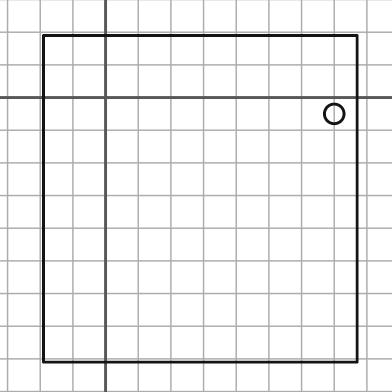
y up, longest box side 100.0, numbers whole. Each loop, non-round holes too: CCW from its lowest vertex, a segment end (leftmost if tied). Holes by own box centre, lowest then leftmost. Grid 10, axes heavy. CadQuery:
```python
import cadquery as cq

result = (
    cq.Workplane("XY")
    .moveTo(-19.0, -81.0)
    .lineTo(77.0, -81.0)
    .lineTo(77.0, 19.0)
    .lineTo(-19.0, 19.0)
    .close()
    .moveTo(70.0, -5.0)
    .circle(3.0)
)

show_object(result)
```